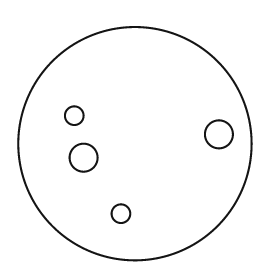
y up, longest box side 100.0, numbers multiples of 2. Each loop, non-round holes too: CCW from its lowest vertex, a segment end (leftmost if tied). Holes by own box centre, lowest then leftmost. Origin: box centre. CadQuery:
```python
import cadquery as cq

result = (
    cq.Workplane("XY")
    .moveTo(0.0, 0.0)
    .circle(50.0)
    .moveTo(-6.0, -30.0)
    .circle(4.0)
    .moveTo(-22.0, -6.0)
    .circle(6.0)
    .moveTo(36.0, 4.0)
    .circle(6.0)
    .moveTo(-26.0, 12.0)
    .circle(4.0)
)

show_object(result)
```